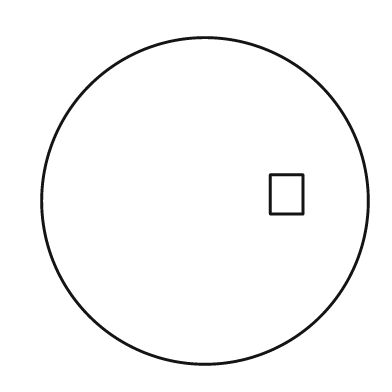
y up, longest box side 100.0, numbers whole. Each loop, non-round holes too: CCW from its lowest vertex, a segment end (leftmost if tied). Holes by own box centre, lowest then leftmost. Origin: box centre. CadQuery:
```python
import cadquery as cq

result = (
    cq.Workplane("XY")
    .moveTo(0.0, 0.0)
    .circle(50.0)
    .moveTo(20.0, -4.0)
    .lineTo(30.0, -4.0)
    .lineTo(30.0, 8.0)
    .lineTo(20.0, 8.0)
    .close()
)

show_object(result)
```